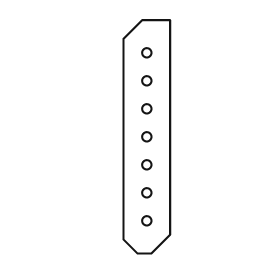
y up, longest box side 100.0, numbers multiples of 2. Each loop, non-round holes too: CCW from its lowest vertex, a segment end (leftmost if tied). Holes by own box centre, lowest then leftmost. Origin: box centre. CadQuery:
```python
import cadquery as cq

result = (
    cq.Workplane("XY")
    .moveTo(-4.0, -50.0)
    .lineTo(2.0, -50.0)
    .lineTo(10.0, -42.0)
    .lineTo(10.0, 50.0)
    .lineTo(-2.0, 50.0)
    .lineTo(-10.0, 42.0)
    .lineTo(-10.0, -44.0)
    .close()
    .moveTo(0.0, -36.0)
    .circle(2.0)
    .moveTo(0.0, -24.0)
    .circle(2.0)
    .moveTo(0.0, -12.0)
    .circle(2.0)
    .moveTo(0.0, 0.0)
    .circle(2.0)
    .moveTo(0.0, 12.0)
    .circle(2.0)
    .moveTo(0.0, 24.0)
    .circle(2.0)
    .moveTo(0.0, 36.0)
    .circle(2.0)
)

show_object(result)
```